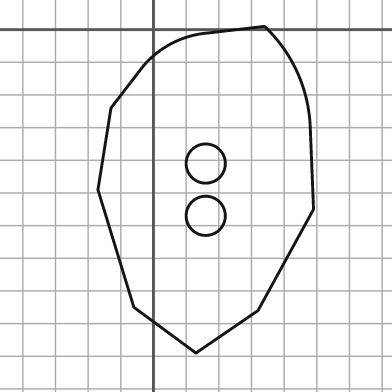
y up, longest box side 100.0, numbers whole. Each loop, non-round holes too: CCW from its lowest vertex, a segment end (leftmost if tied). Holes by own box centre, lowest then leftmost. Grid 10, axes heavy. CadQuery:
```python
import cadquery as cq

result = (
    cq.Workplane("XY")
    .moveTo(13.0, -99.0)
    .lineTo(32.0, -86.0)
    .lineTo(49.0, -55.0)
    .lineTo(48.0, -30.0)
    .threePointArc((44.0, -13.0), (34.0, 1.0))
    .lineTo(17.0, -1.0)
    .threePointArc((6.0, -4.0), (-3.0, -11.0))
    .lineTo(-13.0, -24.0)
    .lineTo(-17.0, -49.0)
    .lineTo(-6.0, -85.0)
    .close()
    .moveTo(16.0, -57.0)
    .circle(6.0)
    .moveTo(16.0, -41.0)
    .circle(6.0)
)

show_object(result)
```